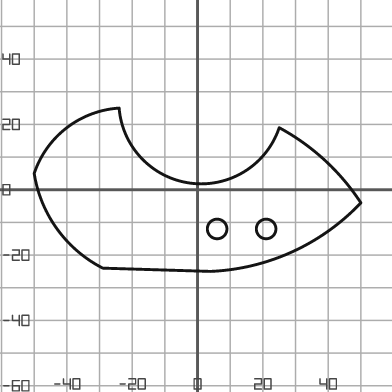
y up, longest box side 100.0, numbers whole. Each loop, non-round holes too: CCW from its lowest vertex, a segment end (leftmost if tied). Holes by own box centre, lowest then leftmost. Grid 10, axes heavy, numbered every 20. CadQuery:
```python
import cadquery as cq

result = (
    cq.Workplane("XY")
    .moveTo(4.0, -25.0)
    .threePointArc((29.0, -19.0), (50.0, -4.0))
    .threePointArc((39.0, 9.0), (25.0, 19.0))
    .threePointArc((-2.0, 2.0), (-24.0, 25.0))
    .threePointArc((-40.0, 19.0), (-50.0, 5.0))
    .threePointArc((-43.0, -12.0), (-29.0, -24.0))
    .close()
    .moveTo(6.0, -12.0)
    .circle(3.0)
    .moveTo(21.0, -12.0)
    .circle(3.0)
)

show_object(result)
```